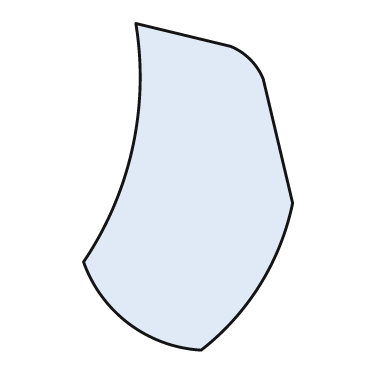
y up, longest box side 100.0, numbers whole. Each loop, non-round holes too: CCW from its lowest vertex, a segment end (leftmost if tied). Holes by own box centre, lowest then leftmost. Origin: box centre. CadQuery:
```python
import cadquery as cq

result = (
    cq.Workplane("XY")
    .moveTo(4.0, -50.0)
    .threePointArc((22.0, -30.0), (32.0, -5.0))
    .lineTo(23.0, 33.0)
    .threePointArc((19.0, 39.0), (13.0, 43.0))
    .lineTo(-16.0, 50.0)
    .threePointArc((-17.0, 12.0), (-32.0, -23.0))
    .threePointArc((-18.0, -42.0), (4.0, -50.0))
    .close()
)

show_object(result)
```